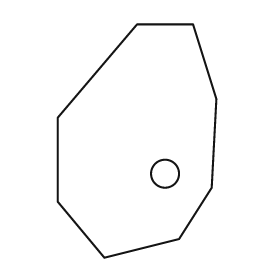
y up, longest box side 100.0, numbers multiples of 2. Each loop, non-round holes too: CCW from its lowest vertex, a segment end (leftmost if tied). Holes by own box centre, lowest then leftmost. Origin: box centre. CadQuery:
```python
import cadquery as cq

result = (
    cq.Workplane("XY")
    .moveTo(-14.0, -50.0)
    .lineTo(18.0, -42.0)
    .lineTo(32.0, -20.0)
    .lineTo(34.0, 18.0)
    .lineTo(24.0, 50.0)
    .lineTo(0.0, 50.0)
    .lineTo(-34.0, 10.0)
    .lineTo(-34.0, -26.0)
    .close()
    .moveTo(12.0, -14.0)
    .circle(6.0)
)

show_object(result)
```